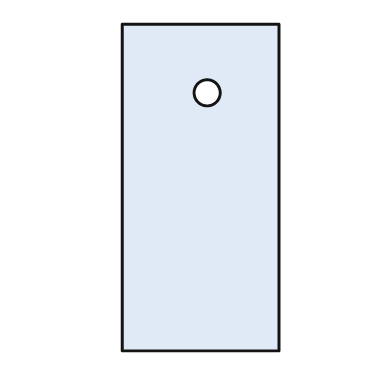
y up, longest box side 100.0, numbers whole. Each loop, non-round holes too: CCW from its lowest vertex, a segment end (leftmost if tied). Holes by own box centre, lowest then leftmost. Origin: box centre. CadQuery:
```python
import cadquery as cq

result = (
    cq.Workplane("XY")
    .moveTo(-24.0, -50.0)
    .lineTo(24.0, -50.0)
    .lineTo(24.0, 50.0)
    .lineTo(-24.0, 50.0)
    .close()
    .moveTo(2.0, 29.0)
    .circle(4.0)
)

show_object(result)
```